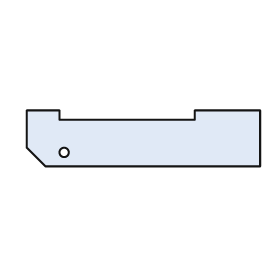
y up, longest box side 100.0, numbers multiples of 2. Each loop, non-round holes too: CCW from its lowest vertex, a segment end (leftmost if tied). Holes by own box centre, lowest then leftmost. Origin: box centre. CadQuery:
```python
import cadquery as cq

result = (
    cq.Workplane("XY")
    .moveTo(-42.0, -12.0)
    .lineTo(50.0, -12.0)
    .lineTo(50.0, 12.0)
    .lineTo(22.0, 12.0)
    .lineTo(22.0, 8.0)
    .lineTo(-36.0, 8.0)
    .lineTo(-36.0, 12.0)
    .lineTo(-50.0, 12.0)
    .lineTo(-50.0, -4.0)
    .close()
    .moveTo(-34.0, -6.0)
    .circle(2.0)
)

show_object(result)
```